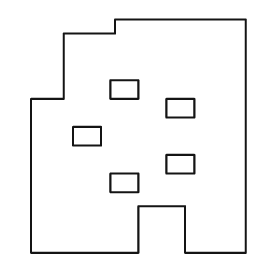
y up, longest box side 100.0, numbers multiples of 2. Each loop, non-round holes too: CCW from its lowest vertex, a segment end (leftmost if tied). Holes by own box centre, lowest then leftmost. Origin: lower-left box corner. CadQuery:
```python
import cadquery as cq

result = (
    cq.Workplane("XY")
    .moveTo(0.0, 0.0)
    .lineTo(46.0, 0.0)
    .lineTo(46.0, 20.0)
    .lineTo(66.0, 20.0)
    .lineTo(66.0, 0.0)
    .lineTo(92.0, 0.0)
    .lineTo(92.0, 100.0)
    .lineTo(36.0, 100.0)
    .lineTo(36.0, 94.0)
    .lineTo(14.0, 94.0)
    .lineTo(14.0, 66.0)
    .lineTo(0.0, 66.0)
    .close()
    .moveTo(34.0, 26.0)
    .lineTo(46.0, 26.0)
    .lineTo(46.0, 34.0)
    .lineTo(34.0, 34.0)
    .close()
    .moveTo(58.0, 34.0)
    .lineTo(70.0, 34.0)
    .lineTo(70.0, 42.0)
    .lineTo(58.0, 42.0)
    .close()
    .moveTo(18.0, 46.0)
    .lineTo(30.0, 46.0)
    .lineTo(30.0, 54.0)
    .lineTo(18.0, 54.0)
    .close()
    .moveTo(58.0, 58.0)
    .lineTo(70.0, 58.0)
    .lineTo(70.0, 66.0)
    .lineTo(58.0, 66.0)
    .close()
    .moveTo(34.0, 66.0)
    .lineTo(46.0, 66.0)
    .lineTo(46.0, 74.0)
    .lineTo(34.0, 74.0)
    .close()
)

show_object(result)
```